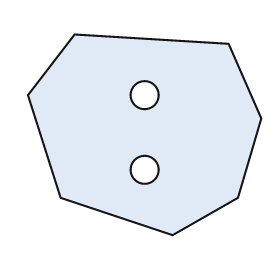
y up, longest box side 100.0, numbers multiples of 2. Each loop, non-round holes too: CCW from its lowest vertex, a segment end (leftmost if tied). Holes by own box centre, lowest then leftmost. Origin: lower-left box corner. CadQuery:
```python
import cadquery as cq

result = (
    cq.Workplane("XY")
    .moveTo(62.0, 0.0)
    .lineTo(90.0, 16.0)
    .lineTo(100.0, 50.0)
    .lineTo(86.0, 82.0)
    .lineTo(20.0, 86.0)
    .lineTo(0.0, 60.0)
    .lineTo(14.0, 16.0)
    .close()
    .moveTo(50.0, 28.0)
    .circle(6.0)
    .moveTo(50.0, 60.0)
    .circle(6.0)
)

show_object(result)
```